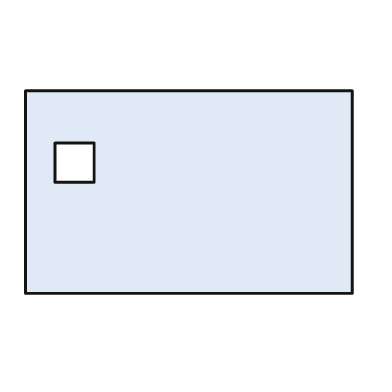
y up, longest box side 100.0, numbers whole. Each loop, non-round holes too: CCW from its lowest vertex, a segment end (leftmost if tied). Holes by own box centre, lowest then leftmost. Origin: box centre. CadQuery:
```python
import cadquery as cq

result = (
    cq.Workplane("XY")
    .moveTo(-50.0, -31.0)
    .lineTo(50.0, -31.0)
    .lineTo(50.0, 31.0)
    .lineTo(-50.0, 31.0)
    .close()
    .moveTo(-41.0, 3.0)
    .lineTo(-29.0, 3.0)
    .lineTo(-29.0, 15.0)
    .lineTo(-41.0, 15.0)
    .close()
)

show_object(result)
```